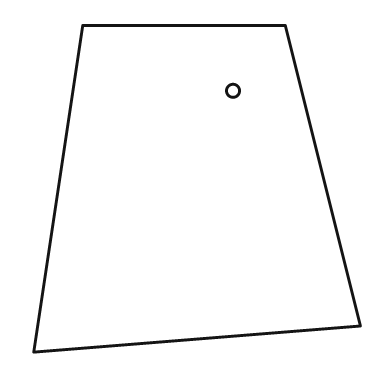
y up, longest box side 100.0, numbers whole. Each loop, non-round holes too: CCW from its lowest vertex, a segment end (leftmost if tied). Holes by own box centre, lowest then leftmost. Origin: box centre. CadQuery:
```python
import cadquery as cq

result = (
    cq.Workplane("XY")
    .moveTo(-50.0, -50.0)
    .lineTo(50.0, -42.0)
    .lineTo(27.0, 50.0)
    .lineTo(-35.0, 50.0)
    .close()
    .moveTo(11.0, 30.0)
    .circle(2.0)
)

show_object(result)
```